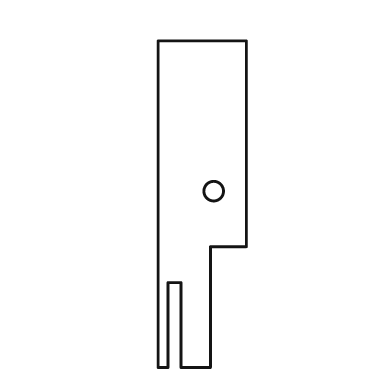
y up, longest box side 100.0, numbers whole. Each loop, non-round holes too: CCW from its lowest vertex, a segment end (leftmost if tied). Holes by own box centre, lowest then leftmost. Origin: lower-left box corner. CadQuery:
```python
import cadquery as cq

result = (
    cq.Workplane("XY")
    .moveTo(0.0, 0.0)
    .lineTo(3.0, 0.0)
    .lineTo(3.0, 26.0)
    .lineTo(7.0, 26.0)
    .lineTo(7.0, 0.0)
    .lineTo(16.0, 0.0)
    .lineTo(16.0, 37.0)
    .lineTo(27.0, 37.0)
    .lineTo(27.0, 100.0)
    .lineTo(0.0, 100.0)
    .close()
    .moveTo(17.0, 54.0)
    .circle(3.0)
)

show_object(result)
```